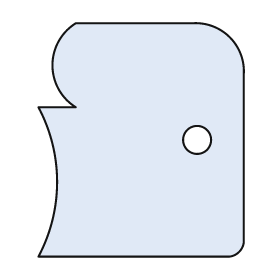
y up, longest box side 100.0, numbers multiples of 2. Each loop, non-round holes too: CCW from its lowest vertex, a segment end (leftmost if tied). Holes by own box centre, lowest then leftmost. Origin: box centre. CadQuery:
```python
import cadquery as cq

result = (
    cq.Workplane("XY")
    .moveTo(-44.0, -50.0)
    .lineTo(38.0, -50.0)
    .threePointArc((42.0, -48.0), (44.0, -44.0))
    .lineTo(44.0, 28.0)
    .threePointArc((38.0, 44.0), (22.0, 50.0))
    .lineTo(-28.0, 50.0)
    .threePointArc((-38.0, 32.0), (-28.0, 14.0))
    .lineTo(-44.0, 14.0)
    .threePointArc((-36.0, -18.0), (-44.0, -50.0))
    .close()
    .moveTo(24.0, 0.0)
    .circle(6.0)
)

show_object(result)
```